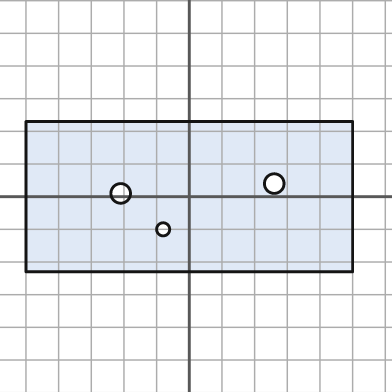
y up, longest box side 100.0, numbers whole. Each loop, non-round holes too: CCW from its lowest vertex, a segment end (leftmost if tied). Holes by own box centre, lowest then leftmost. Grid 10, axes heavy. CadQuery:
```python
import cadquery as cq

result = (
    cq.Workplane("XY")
    .moveTo(-50.0, -23.0)
    .lineTo(50.0, -23.0)
    .lineTo(50.0, 23.0)
    .lineTo(-50.0, 23.0)
    .close()
    .moveTo(-8.0, -10.0)
    .circle(2.0)
    .moveTo(-21.0, 1.0)
    .circle(3.0)
    .moveTo(26.0, 4.0)
    .circle(3.0)
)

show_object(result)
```